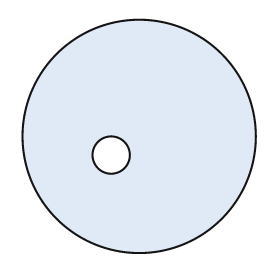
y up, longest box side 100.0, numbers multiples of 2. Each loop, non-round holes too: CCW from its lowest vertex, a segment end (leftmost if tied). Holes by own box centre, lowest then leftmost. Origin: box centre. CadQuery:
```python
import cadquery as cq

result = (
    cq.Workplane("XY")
    .moveTo(0.0, 0.0)
    .circle(50.0)
    .moveTo(-12.0, -8.0)
    .circle(8.0)
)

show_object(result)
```